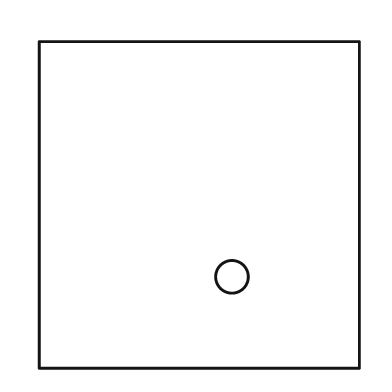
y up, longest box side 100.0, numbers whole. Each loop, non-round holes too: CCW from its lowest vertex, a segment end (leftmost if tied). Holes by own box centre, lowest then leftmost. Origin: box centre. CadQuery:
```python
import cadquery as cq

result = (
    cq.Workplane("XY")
    .moveTo(-49.0, -50.0)
    .lineTo(49.0, -50.0)
    .lineTo(49.0, 50.0)
    .lineTo(-49.0, 50.0)
    .close()
    .moveTo(10.0, -22.0)
    .circle(5.0)
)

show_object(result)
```